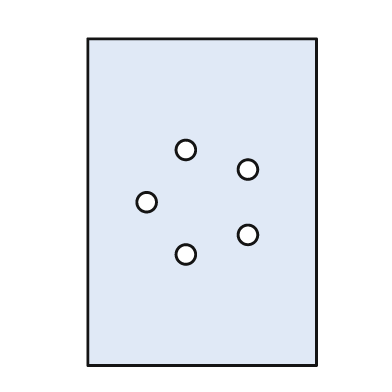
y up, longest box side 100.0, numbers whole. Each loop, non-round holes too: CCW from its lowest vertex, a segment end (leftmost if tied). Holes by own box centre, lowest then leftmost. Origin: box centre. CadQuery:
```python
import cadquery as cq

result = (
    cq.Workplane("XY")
    .moveTo(-35.0, -50.0)
    .lineTo(35.0, -50.0)
    .lineTo(35.0, 50.0)
    .lineTo(-35.0, 50.0)
    .close()
    .moveTo(-5.0, -16.0)
    .circle(3.0)
    .moveTo(14.0, -10.0)
    .circle(3.0)
    .moveTo(-17.0, 0.0)
    .circle(3.0)
    .moveTo(14.0, 10.0)
    .circle(3.0)
    .moveTo(-5.0, 16.0)
    .circle(3.0)
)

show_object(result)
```